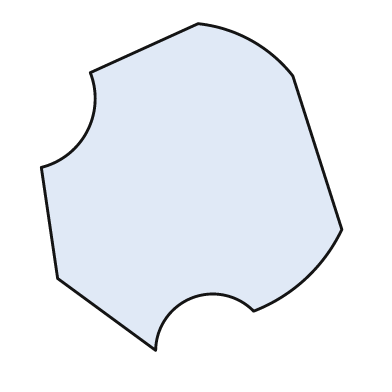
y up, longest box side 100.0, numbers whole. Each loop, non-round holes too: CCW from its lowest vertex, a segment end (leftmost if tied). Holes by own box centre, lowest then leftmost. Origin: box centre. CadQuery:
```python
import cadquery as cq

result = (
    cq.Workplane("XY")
    .moveTo(-11.0, -50.0)
    .threePointArc((0.0, -34.0), (19.0, -38.0))
    .threePointArc((35.0, -28.0), (46.0, -13.0))
    .lineTo(31.0, 34.0)
    .threePointArc((18.0, 45.0), (2.0, 50.0))
    .lineTo(-31.0, 35.0)
    .threePointArc((-32.0, 17.0), (-46.0, 6.0))
    .lineTo(-41.0, -28.0)
    .close()
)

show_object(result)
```